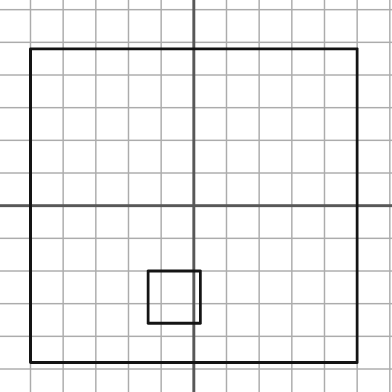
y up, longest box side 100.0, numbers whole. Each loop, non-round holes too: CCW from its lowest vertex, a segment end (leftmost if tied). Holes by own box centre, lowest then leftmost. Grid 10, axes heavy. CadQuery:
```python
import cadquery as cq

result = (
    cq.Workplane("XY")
    .moveTo(-50.0, -48.0)
    .lineTo(50.0, -48.0)
    .lineTo(50.0, 48.0)
    .lineTo(-50.0, 48.0)
    .close()
    .moveTo(-14.0, -36.0)
    .lineTo(2.0, -36.0)
    .lineTo(2.0, -20.0)
    .lineTo(-14.0, -20.0)
    .close()
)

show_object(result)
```